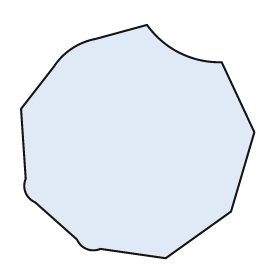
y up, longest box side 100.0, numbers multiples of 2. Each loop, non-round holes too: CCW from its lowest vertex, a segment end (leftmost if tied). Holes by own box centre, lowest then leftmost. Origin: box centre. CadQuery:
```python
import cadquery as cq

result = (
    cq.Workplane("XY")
    .moveTo(12.0, -50.0)
    .lineTo(40.0, -30.0)
    .lineTo(50.0, 4.0)
    .lineTo(36.0, 34.0)
    .threePointArc((18.0, 38.0), (4.0, 50.0))
    .lineTo(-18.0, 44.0)
    .threePointArc((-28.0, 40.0), (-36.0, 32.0))
    .lineTo(-50.0, 14.0)
    .lineTo(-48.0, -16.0)
    .threePointArc((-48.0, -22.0), (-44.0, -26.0))
    .lineTo(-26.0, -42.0)
    .threePointArc((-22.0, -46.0), (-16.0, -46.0))
    .close()
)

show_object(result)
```